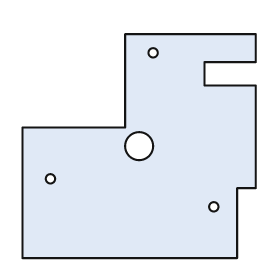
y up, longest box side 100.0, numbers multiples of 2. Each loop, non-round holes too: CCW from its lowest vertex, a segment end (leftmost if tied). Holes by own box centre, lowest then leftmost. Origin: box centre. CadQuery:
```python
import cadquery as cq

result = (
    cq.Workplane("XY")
    .moveTo(-50.0, -48.0)
    .lineTo(42.0, -48.0)
    .lineTo(42.0, -18.0)
    .lineTo(50.0, -18.0)
    .lineTo(50.0, 26.0)
    .lineTo(28.0, 26.0)
    .lineTo(28.0, 36.0)
    .lineTo(50.0, 36.0)
    .lineTo(50.0, 48.0)
    .lineTo(-6.0, 48.0)
    .lineTo(-6.0, 8.0)
    .lineTo(-50.0, 8.0)
    .close()
    .moveTo(32.0, -26.0)
    .circle(2.0)
    .moveTo(-38.0, -14.0)
    .circle(2.0)
    .moveTo(0.0, 0.0)
    .circle(6.0)
    .moveTo(6.0, 40.0)
    .circle(2.0)
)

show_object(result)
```